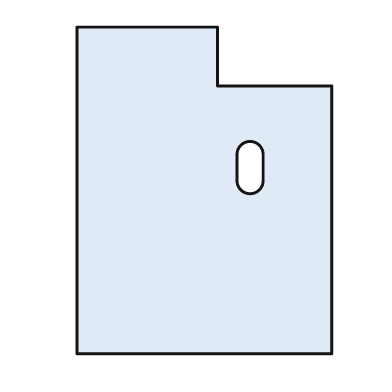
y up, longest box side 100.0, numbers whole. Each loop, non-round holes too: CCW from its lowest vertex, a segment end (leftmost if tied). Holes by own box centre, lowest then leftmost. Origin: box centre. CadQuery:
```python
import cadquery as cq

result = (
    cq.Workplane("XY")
    .moveTo(-39.0, -50.0)
    .lineTo(39.0, -50.0)
    .lineTo(39.0, 32.0)
    .lineTo(4.0, 32.0)
    .lineTo(4.0, 50.0)
    .lineTo(-39.0, 50.0)
    .close()
    .moveTo(10.0, 3.0)
    .threePointArc((14.0, -1.0), (18.0, 3.0))
    .lineTo(18.0, 11.0)
    .threePointArc((14.0, 15.0), (10.0, 11.0))
    .close()
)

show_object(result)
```